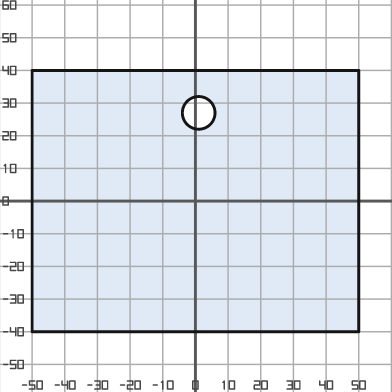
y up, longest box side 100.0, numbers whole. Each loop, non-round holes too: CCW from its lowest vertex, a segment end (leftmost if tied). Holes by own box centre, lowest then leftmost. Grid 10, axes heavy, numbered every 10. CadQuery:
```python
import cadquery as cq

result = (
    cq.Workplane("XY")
    .moveTo(-50.0, -40.0)
    .lineTo(50.0, -40.0)
    .lineTo(50.0, 40.0)
    .lineTo(-50.0, 40.0)
    .close()
    .moveTo(1.0, 27.0)
    .circle(5.0)
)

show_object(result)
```